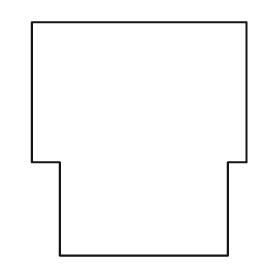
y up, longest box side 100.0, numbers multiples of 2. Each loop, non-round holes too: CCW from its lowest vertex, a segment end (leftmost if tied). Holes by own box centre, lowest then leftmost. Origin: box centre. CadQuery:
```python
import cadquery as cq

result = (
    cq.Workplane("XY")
    .moveTo(-34.0, -50.0)
    .lineTo(38.0, -50.0)
    .lineTo(38.0, -10.0)
    .lineTo(46.0, -10.0)
    .lineTo(46.0, 50.0)
    .lineTo(-46.0, 50.0)
    .lineTo(-46.0, -10.0)
    .lineTo(-34.0, -10.0)
    .close()
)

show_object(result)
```